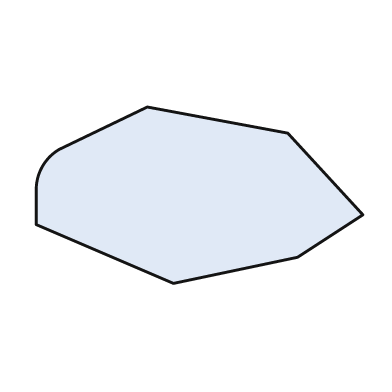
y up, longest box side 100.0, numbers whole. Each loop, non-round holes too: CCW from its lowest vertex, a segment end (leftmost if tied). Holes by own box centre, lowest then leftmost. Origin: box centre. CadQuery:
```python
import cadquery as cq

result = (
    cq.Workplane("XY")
    .moveTo(-8.0, -27.0)
    .lineTo(30.0, -19.0)
    .lineTo(50.0, -6.0)
    .lineTo(27.0, 19.0)
    .lineTo(-16.0, 27.0)
    .lineTo(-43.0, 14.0)
    .threePointArc((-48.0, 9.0), (-50.0, 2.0))
    .lineTo(-50.0, -9.0)
    .close()
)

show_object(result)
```